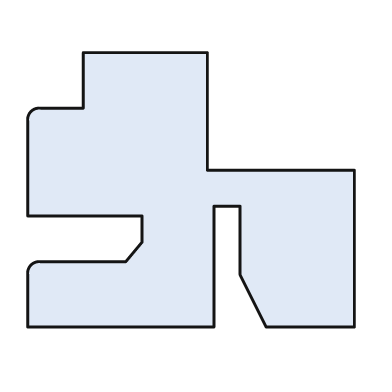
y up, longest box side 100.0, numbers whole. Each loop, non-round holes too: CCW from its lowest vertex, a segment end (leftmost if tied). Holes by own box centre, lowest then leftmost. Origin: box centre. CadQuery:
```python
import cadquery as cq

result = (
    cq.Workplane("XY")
    .moveTo(-50.0, -42.0)
    .lineTo(7.0, -42.0)
    .lineTo(7.0, -5.0)
    .lineTo(15.0, -5.0)
    .lineTo(15.0, -26.0)
    .lineTo(23.0, -42.0)
    .lineTo(50.0, -42.0)
    .lineTo(50.0, 6.0)
    .lineTo(5.0, 6.0)
    .lineTo(5.0, 42.0)
    .lineTo(-33.0, 42.0)
    .lineTo(-33.0, 25.0)
    .lineTo(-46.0, 25.0)
    .threePointArc((-49.0, 24.0), (-50.0, 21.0))
    .lineTo(-50.0, -8.0)
    .lineTo(-15.0, -8.0)
    .lineTo(-15.0, -16.0)
    .lineTo(-20.0, -22.0)
    .lineTo(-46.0, -22.0)
    .threePointArc((-49.0, -23.0), (-50.0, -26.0))
    .close()
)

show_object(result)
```